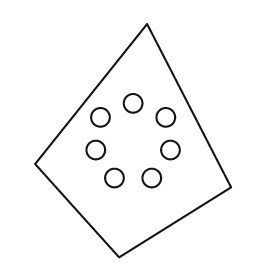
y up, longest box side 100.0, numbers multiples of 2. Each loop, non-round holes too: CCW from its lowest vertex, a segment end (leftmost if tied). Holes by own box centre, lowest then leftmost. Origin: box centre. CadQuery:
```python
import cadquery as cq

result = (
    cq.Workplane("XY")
    .moveTo(-6.0, -50.0)
    .lineTo(42.0, -20.0)
    .lineTo(6.0, 50.0)
    .lineTo(-42.0, -10.0)
    .close()
    .moveTo(-8.0, -16.0)
    .circle(4.0)
    .moveTo(8.0, -16.0)
    .circle(4.0)
    .moveTo(-16.0, -4.0)
    .circle(4.0)
    .moveTo(16.0, -4.0)
    .circle(4.0)
    .moveTo(-14.0, 10.0)
    .circle(4.0)
    .moveTo(14.0, 10.0)
    .circle(4.0)
    .moveTo(0.0, 16.0)
    .circle(4.0)
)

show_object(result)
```